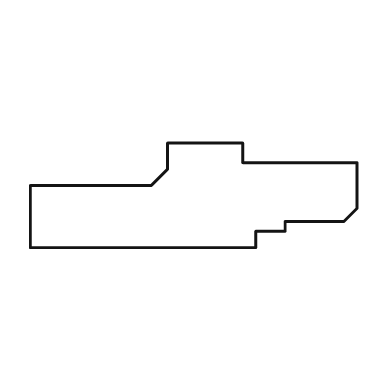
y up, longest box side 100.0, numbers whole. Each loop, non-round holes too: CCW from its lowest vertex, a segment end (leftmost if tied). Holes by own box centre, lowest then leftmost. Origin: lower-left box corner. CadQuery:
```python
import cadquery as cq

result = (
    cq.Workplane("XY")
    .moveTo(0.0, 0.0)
    .lineTo(69.0, 0.0)
    .lineTo(69.0, 5.0)
    .lineTo(78.0, 5.0)
    .lineTo(78.0, 8.0)
    .lineTo(96.0, 8.0)
    .lineTo(100.0, 12.0)
    .lineTo(100.0, 26.0)
    .lineTo(65.0, 26.0)
    .lineTo(65.0, 32.0)
    .lineTo(42.0, 32.0)
    .lineTo(42.0, 24.0)
    .lineTo(37.0, 19.0)
    .lineTo(0.0, 19.0)
    .close()
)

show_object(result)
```